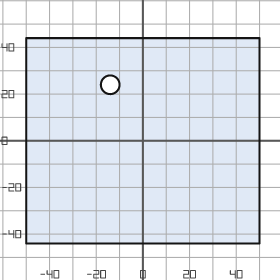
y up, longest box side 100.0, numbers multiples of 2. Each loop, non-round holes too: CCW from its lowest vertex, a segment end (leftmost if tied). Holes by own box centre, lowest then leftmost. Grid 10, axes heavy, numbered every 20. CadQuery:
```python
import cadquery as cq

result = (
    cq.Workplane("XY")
    .moveTo(-50.0, -44.0)
    .lineTo(50.0, -44.0)
    .lineTo(50.0, 44.0)
    .lineTo(-50.0, 44.0)
    .close()
    .moveTo(-14.0, 24.0)
    .circle(4.0)
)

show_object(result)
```